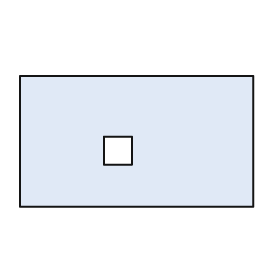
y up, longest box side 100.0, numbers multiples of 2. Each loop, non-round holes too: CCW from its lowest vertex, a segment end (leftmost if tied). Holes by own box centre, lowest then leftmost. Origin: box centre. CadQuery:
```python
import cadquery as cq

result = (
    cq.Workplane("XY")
    .moveTo(-50.0, -28.0)
    .lineTo(50.0, -28.0)
    .lineTo(50.0, 28.0)
    .lineTo(-50.0, 28.0)
    .close()
    .moveTo(-14.0, -10.0)
    .lineTo(-2.0, -10.0)
    .lineTo(-2.0, 2.0)
    .lineTo(-14.0, 2.0)
    .close()
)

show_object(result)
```